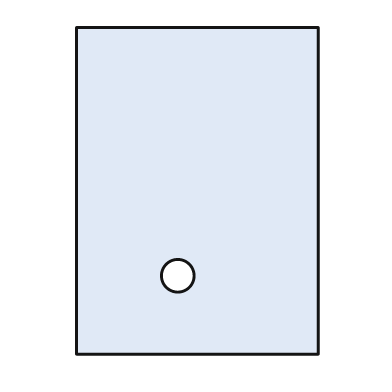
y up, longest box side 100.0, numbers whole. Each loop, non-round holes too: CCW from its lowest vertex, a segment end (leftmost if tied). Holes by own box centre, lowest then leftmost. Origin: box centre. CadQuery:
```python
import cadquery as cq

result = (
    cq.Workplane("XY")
    .moveTo(-37.0, -50.0)
    .lineTo(37.0, -50.0)
    .lineTo(37.0, 50.0)
    .lineTo(-37.0, 50.0)
    .close()
    .moveTo(-6.0, -26.0)
    .circle(5.0)
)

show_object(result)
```